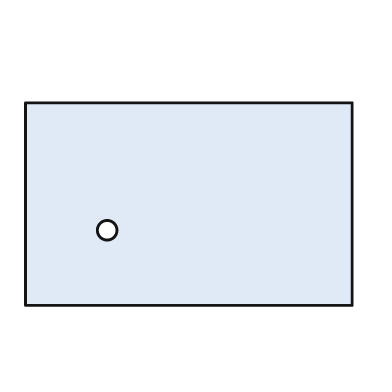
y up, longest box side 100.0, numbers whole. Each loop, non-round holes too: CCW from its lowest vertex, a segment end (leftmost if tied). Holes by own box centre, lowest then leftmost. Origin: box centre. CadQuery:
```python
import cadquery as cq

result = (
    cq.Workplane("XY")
    .moveTo(-50.0, -31.0)
    .lineTo(50.0, -31.0)
    .lineTo(50.0, 31.0)
    .lineTo(-50.0, 31.0)
    .close()
    .moveTo(-25.0, -8.0)
    .circle(3.0)
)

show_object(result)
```